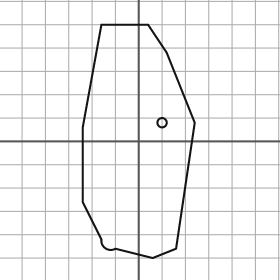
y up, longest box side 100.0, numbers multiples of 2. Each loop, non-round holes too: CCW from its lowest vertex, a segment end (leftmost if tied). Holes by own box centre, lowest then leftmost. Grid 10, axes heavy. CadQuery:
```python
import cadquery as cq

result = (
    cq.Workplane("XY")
    .moveTo(6.0, -50.0)
    .lineTo(16.0, -46.0)
    .lineTo(24.0, 8.0)
    .lineTo(12.0, 38.0)
    .lineTo(4.0, 50.0)
    .lineTo(-16.0, 50.0)
    .lineTo(-24.0, 6.0)
    .lineTo(-24.0, -26.0)
    .lineTo(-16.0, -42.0)
    .threePointArc((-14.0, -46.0), (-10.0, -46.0))
    .close()
    .moveTo(10.0, 8.0)
    .circle(2.0)
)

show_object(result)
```